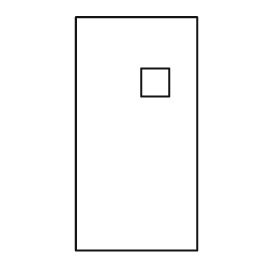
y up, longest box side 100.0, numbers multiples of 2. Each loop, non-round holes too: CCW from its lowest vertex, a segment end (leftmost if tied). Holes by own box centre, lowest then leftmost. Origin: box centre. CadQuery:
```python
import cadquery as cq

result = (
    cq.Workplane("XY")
    .moveTo(-26.0, -50.0)
    .lineTo(26.0, -50.0)
    .lineTo(26.0, 50.0)
    .lineTo(-26.0, 50.0)
    .close()
    .moveTo(2.0, 16.0)
    .lineTo(14.0, 16.0)
    .lineTo(14.0, 28.0)
    .lineTo(2.0, 28.0)
    .close()
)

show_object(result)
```